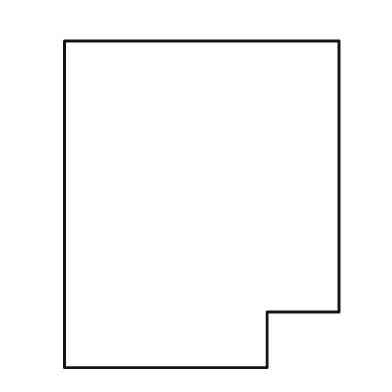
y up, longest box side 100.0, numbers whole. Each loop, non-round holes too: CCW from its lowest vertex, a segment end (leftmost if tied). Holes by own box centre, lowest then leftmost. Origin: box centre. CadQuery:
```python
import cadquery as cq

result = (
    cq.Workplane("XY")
    .moveTo(-42.0, -50.0)
    .lineTo(20.0, -50.0)
    .lineTo(20.0, -33.0)
    .lineTo(42.0, -33.0)
    .lineTo(42.0, 50.0)
    .lineTo(-42.0, 50.0)
    .close()
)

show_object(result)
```